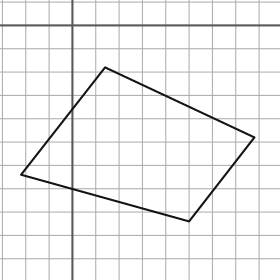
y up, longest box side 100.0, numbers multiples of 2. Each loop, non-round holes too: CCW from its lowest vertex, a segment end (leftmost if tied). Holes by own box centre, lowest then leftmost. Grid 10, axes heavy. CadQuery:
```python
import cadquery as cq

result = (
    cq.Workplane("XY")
    .moveTo(50.0, -84.0)
    .lineTo(78.0, -48.0)
    .lineTo(14.0, -18.0)
    .lineTo(-22.0, -64.0)
    .close()
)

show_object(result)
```